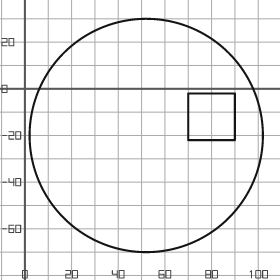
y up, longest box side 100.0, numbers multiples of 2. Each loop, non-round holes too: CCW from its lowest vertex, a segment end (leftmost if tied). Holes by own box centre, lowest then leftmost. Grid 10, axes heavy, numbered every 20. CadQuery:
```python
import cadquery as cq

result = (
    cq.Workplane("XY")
    .moveTo(52.0, -20.0)
    .circle(50.0)
    .moveTo(70.0, -22.0)
    .lineTo(90.0, -22.0)
    .lineTo(90.0, -2.0)
    .lineTo(70.0, -2.0)
    .close()
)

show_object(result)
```